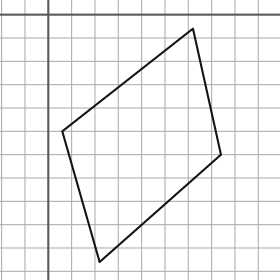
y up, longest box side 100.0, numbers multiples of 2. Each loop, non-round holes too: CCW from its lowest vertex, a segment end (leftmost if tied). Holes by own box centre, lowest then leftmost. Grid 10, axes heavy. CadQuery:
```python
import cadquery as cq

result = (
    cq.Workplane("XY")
    .moveTo(22.0, -106.0)
    .lineTo(74.0, -60.0)
    .lineTo(62.0, -6.0)
    .lineTo(6.0, -50.0)
    .close()
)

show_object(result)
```